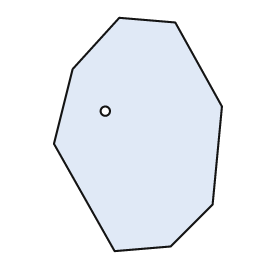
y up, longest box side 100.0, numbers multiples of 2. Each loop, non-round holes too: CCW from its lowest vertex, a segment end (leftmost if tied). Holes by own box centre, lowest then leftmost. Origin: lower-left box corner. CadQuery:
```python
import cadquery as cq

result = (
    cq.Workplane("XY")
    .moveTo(26.0, 0.0)
    .lineTo(50.0, 2.0)
    .lineTo(68.0, 20.0)
    .lineTo(72.0, 62.0)
    .lineTo(52.0, 98.0)
    .lineTo(28.0, 100.0)
    .lineTo(8.0, 78.0)
    .lineTo(0.0, 46.0)
    .close()
    .moveTo(22.0, 60.0)
    .circle(2.0)
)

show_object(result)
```